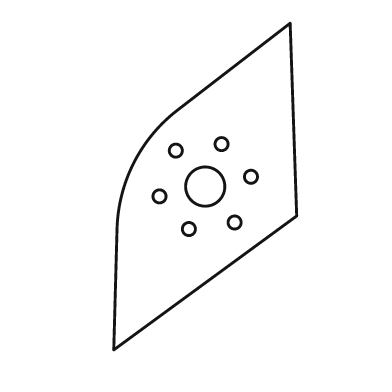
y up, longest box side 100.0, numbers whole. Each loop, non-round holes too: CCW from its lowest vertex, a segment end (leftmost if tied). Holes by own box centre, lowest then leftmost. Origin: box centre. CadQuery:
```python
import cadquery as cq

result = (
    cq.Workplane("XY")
    .moveTo(-28.0, -50.0)
    .lineTo(28.0, -9.0)
    .lineTo(26.0, 50.0)
    .lineTo(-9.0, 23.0)
    .threePointArc((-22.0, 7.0), (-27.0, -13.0))
    .close()
    .moveTo(-5.0, -13.0)
    .circle(2.0)
    .moveTo(9.0, -11.0)
    .circle(2.0)
    .moveTo(-14.0, -3.0)
    .circle(2.0)
    .moveTo(0.0, 0.0)
    .circle(6.0)
    .moveTo(14.0, 3.0)
    .circle(2.0)
    .moveTo(-9.0, 11.0)
    .circle(2.0)
    .moveTo(5.0, 13.0)
    .circle(2.0)
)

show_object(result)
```